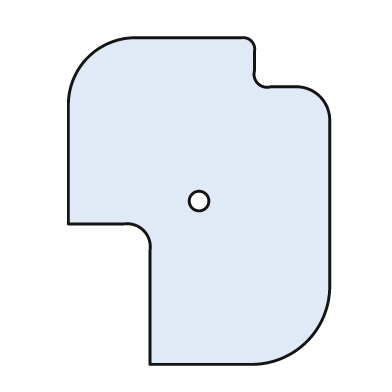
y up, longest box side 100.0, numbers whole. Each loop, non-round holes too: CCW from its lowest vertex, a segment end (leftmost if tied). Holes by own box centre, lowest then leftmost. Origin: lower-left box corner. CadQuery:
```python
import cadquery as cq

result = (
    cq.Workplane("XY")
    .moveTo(25.0, 0.0)
    .lineTo(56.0, 0.0)
    .threePointArc((73.0, 7.0), (80.0, 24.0))
    .lineTo(80.0, 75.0)
    .threePointArc((77.0, 82.0), (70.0, 85.0))
    .lineTo(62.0, 85.0)
    .threePointArc((58.0, 86.0), (57.0, 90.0))
    .lineTo(57.0, 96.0)
    .threePointArc((56.0, 99.0), (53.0, 100.0))
    .lineTo(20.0, 100.0)
    .threePointArc((6.0, 94.0), (0.0, 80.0))
    .lineTo(0.0, 43.0)
    .lineTo(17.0, 43.0)
    .threePointArc((23.0, 41.0), (25.0, 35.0))
    .close()
    .moveTo(40.0, 50.0)
    .circle(3.0)
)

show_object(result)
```